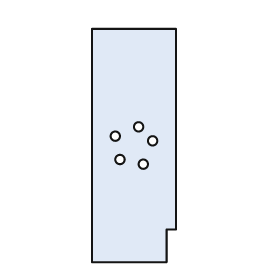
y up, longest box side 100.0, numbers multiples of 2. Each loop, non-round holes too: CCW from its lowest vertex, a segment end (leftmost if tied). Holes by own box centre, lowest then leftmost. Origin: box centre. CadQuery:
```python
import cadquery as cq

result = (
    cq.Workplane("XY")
    .moveTo(-18.0, -50.0)
    .lineTo(14.0, -50.0)
    .lineTo(14.0, -36.0)
    .lineTo(18.0, -36.0)
    .lineTo(18.0, 50.0)
    .lineTo(-18.0, 50.0)
    .close()
    .moveTo(4.0, -8.0)
    .circle(2.0)
    .moveTo(-6.0, -6.0)
    .circle(2.0)
    .moveTo(8.0, 2.0)
    .circle(2.0)
    .moveTo(-8.0, 4.0)
    .circle(2.0)
    .moveTo(2.0, 8.0)
    .circle(2.0)
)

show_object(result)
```